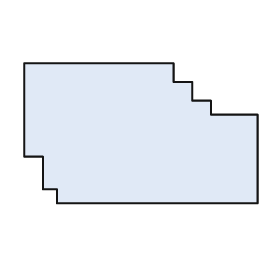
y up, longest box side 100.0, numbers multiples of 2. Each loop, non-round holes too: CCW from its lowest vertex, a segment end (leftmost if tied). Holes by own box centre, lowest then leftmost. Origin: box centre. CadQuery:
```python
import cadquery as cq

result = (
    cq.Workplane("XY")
    .moveTo(-36.0, -30.0)
    .lineTo(50.0, -30.0)
    .lineTo(50.0, 8.0)
    .lineTo(30.0, 8.0)
    .lineTo(30.0, 14.0)
    .lineTo(22.0, 14.0)
    .lineTo(22.0, 22.0)
    .lineTo(14.0, 22.0)
    .lineTo(14.0, 30.0)
    .lineTo(-50.0, 30.0)
    .lineTo(-50.0, -10.0)
    .lineTo(-42.0, -10.0)
    .lineTo(-42.0, -24.0)
    .lineTo(-36.0, -24.0)
    .close()
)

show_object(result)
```